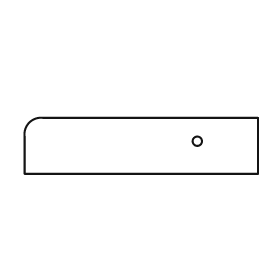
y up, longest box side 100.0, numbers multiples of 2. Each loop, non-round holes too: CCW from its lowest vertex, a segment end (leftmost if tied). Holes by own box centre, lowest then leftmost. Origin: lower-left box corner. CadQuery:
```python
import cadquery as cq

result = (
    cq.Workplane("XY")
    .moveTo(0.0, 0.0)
    .lineTo(100.0, 0.0)
    .lineTo(100.0, 24.0)
    .lineTo(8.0, 24.0)
    .threePointArc((2.0, 22.0), (0.0, 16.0))
    .close()
    .moveTo(74.0, 14.0)
    .circle(2.0)
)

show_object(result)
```